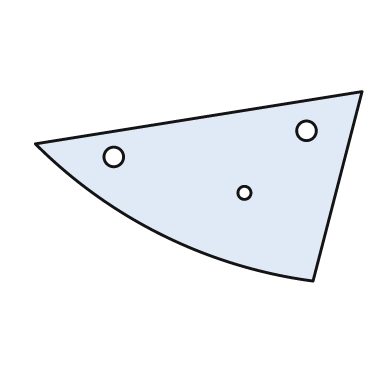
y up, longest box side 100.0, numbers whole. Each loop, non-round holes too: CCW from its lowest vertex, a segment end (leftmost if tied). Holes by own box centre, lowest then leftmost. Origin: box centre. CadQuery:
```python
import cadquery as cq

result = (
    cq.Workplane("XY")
    .moveTo(35.0, -29.0)
    .lineTo(50.0, 29.0)
    .lineTo(-50.0, 13.0)
    .threePointArc((-11.0, -15.0), (35.0, -29.0))
    .close()
    .moveTo(14.0, -2.0)
    .circle(2.0)
    .moveTo(-26.0, 9.0)
    .circle(3.0)
    .moveTo(33.0, 17.0)
    .circle(3.0)
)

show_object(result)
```